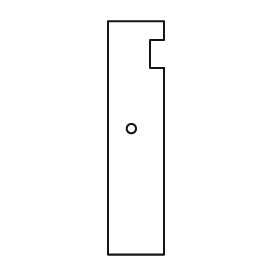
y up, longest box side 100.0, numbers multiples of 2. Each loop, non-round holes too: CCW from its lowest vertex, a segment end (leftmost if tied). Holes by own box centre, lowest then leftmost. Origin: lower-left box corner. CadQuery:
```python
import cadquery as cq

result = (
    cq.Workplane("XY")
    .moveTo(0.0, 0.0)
    .lineTo(24.0, 0.0)
    .lineTo(24.0, 80.0)
    .lineTo(18.0, 80.0)
    .lineTo(18.0, 92.0)
    .lineTo(24.0, 92.0)
    .lineTo(24.0, 100.0)
    .lineTo(0.0, 100.0)
    .close()
    .moveTo(10.0, 54.0)
    .circle(2.0)
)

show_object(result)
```